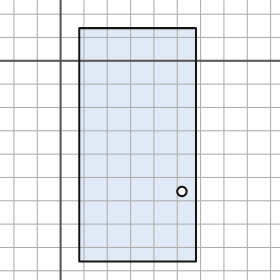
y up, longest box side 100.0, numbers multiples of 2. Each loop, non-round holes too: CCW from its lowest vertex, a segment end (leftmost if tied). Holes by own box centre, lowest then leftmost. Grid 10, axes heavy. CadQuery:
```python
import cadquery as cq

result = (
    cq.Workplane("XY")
    .moveTo(8.0, -86.0)
    .lineTo(58.0, -86.0)
    .lineTo(58.0, 14.0)
    .lineTo(8.0, 14.0)
    .close()
    .moveTo(52.0, -56.0)
    .circle(2.0)
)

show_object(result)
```